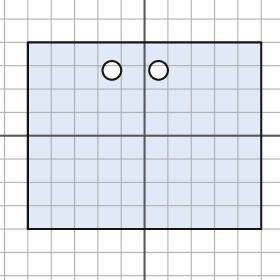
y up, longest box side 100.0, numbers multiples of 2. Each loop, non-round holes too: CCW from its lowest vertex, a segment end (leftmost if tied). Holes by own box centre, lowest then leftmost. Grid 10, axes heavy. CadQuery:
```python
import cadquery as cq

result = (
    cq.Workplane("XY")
    .moveTo(-50.0, -40.0)
    .lineTo(50.0, -40.0)
    .lineTo(50.0, 40.0)
    .lineTo(-50.0, 40.0)
    .close()
    .moveTo(-14.0, 28.0)
    .circle(4.0)
    .moveTo(6.0, 28.0)
    .circle(4.0)
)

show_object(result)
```